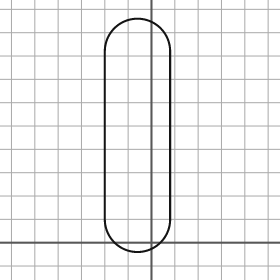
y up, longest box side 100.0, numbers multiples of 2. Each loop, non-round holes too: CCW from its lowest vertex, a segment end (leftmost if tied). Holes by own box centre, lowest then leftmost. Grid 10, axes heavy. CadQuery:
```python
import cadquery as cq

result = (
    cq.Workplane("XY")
    .moveTo(-20.0, 10.0)
    .threePointArc((-6.0, -4.0), (8.0, 10.0))
    .lineTo(8.0, 82.0)
    .threePointArc((-6.0, 96.0), (-20.0, 82.0))
    .close()
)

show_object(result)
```